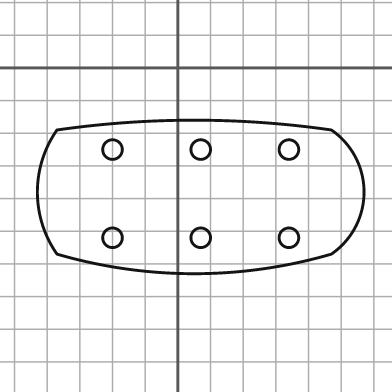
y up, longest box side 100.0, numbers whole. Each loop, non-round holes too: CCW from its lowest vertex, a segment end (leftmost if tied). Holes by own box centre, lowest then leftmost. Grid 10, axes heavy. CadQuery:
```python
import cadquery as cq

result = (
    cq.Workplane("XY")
    .moveTo(-37.0, -57.0)
    .threePointArc((5.0, -63.0), (47.0, -57.0))
    .threePointArc((57.0, -38.0), (47.0, -19.0))
    .threePointArc((5.0, -16.0), (-37.0, -19.0))
    .threePointArc((-43.0, -38.0), (-37.0, -57.0))
    .close()
    .moveTo(-20.0, -52.0)
    .circle(3.0)
    .moveTo(7.0, -52.0)
    .circle(3.0)
    .moveTo(34.0, -52.0)
    .circle(3.0)
    .moveTo(-20.0, -25.0)
    .circle(3.0)
    .moveTo(7.0, -25.0)
    .circle(3.0)
    .moveTo(34.0, -25.0)
    .circle(3.0)
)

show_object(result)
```